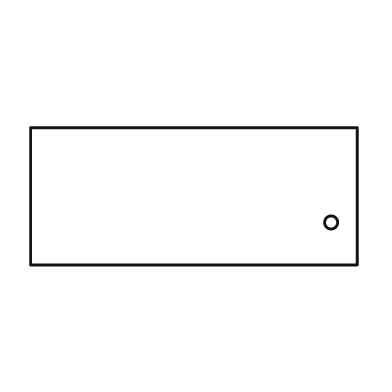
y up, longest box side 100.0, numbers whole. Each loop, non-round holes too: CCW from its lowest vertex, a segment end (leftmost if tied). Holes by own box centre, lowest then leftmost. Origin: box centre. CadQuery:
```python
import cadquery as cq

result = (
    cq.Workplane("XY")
    .moveTo(-50.0, -21.0)
    .lineTo(50.0, -21.0)
    .lineTo(50.0, 21.0)
    .lineTo(-50.0, 21.0)
    .close()
    .moveTo(42.0, -8.0)
    .circle(2.0)
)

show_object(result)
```